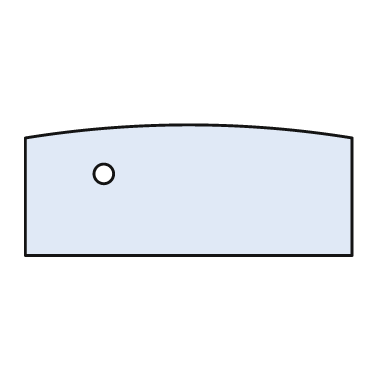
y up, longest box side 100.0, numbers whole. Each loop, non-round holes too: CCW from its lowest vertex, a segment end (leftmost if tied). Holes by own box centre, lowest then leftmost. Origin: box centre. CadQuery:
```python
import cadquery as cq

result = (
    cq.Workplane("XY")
    .moveTo(-50.0, -20.0)
    .lineTo(50.0, -20.0)
    .lineTo(50.0, 16.0)
    .threePointArc((0.0, 20.0), (-50.0, 16.0))
    .close()
    .moveTo(-26.0, 5.0)
    .circle(3.0)
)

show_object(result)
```